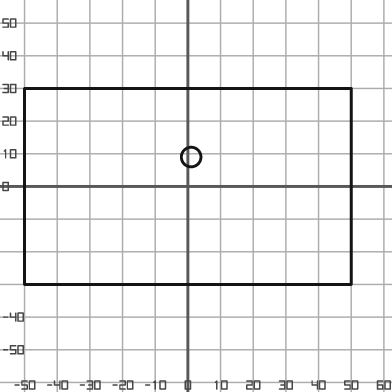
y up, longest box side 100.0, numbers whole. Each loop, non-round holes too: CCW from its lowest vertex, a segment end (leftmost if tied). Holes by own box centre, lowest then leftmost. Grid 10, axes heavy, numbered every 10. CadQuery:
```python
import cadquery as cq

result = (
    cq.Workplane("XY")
    .moveTo(-50.0, -30.0)
    .lineTo(50.0, -30.0)
    .lineTo(50.0, 30.0)
    .lineTo(-50.0, 30.0)
    .close()
    .moveTo(1.0, 9.0)
    .circle(3.0)
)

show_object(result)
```